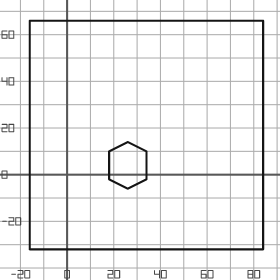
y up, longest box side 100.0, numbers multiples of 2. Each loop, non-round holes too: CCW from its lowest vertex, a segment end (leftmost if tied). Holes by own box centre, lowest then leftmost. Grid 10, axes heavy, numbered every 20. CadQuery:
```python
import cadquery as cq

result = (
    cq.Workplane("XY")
    .moveTo(-16.0, -32.0)
    .lineTo(84.0, -32.0)
    .lineTo(84.0, 66.0)
    .lineTo(-16.0, 66.0)
    .close()
    .moveTo(26.0, -6.0)
    .lineTo(34.0, -2.0)
    .lineTo(34.0, 10.0)
    .lineTo(26.0, 14.0)
    .lineTo(18.0, 10.0)
    .lineTo(18.0, -2.0)
    .close()
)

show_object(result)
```